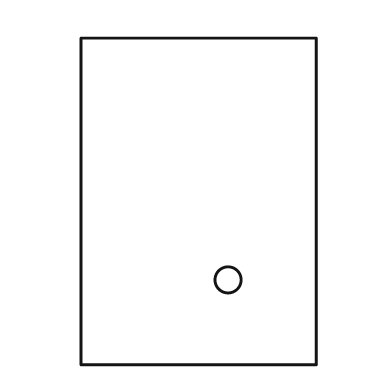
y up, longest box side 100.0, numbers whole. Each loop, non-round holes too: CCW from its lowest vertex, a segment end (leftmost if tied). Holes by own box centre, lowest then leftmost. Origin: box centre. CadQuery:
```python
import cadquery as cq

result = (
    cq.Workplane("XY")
    .moveTo(-36.0, -50.0)
    .lineTo(36.0, -50.0)
    .lineTo(36.0, 50.0)
    .lineTo(-36.0, 50.0)
    .close()
    .moveTo(9.0, -24.0)
    .circle(4.0)
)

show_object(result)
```